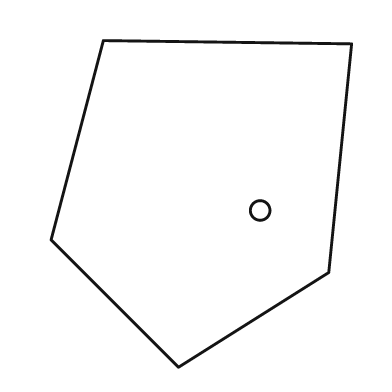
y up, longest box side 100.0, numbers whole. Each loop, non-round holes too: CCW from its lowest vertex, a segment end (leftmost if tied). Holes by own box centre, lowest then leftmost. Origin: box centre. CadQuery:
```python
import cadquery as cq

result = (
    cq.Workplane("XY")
    .moveTo(-7.0, -50.0)
    .lineTo(39.0, -21.0)
    .lineTo(46.0, 49.0)
    .lineTo(-30.0, 50.0)
    .lineTo(-46.0, -11.0)
    .close()
    .moveTo(18.0, -2.0)
    .circle(3.0)
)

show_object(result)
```